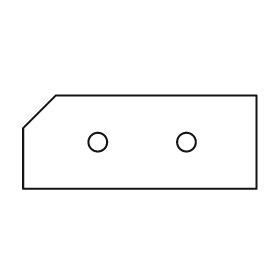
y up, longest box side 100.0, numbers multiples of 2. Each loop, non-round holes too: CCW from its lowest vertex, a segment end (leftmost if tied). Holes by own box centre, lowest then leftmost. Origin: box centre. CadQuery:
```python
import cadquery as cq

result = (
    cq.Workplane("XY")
    .moveTo(-50.0, -20.0)
    .lineTo(50.0, -20.0)
    .lineTo(50.0, 20.0)
    .lineTo(-36.0, 20.0)
    .lineTo(-50.0, 6.0)
    .close()
    .moveTo(-18.0, 0.0)
    .circle(4.0)
    .moveTo(20.0, 0.0)
    .circle(4.0)
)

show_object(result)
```